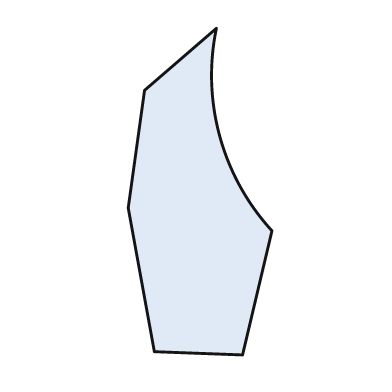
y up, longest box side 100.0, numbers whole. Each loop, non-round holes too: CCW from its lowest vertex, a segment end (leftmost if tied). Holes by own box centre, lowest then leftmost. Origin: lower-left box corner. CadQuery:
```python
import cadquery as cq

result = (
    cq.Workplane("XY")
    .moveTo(35.0, 0.0)
    .lineTo(44.0, 38.0)
    .threePointArc((28.0, 67.0), (27.0, 100.0))
    .lineTo(5.0, 81.0)
    .lineTo(0.0, 45.0)
    .lineTo(8.0, 1.0)
    .close()
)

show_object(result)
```